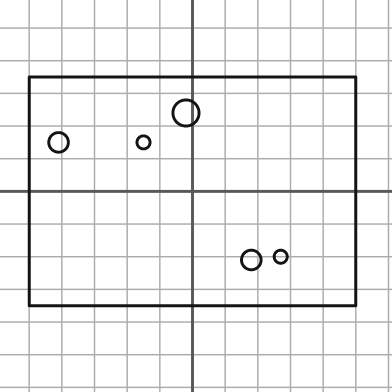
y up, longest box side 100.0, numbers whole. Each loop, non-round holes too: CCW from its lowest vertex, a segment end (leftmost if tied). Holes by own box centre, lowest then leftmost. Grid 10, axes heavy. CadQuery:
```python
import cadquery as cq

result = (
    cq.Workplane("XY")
    .moveTo(-50.0, -35.0)
    .lineTo(50.0, -35.0)
    .lineTo(50.0, 35.0)
    .lineTo(-50.0, 35.0)
    .close()
    .moveTo(18.0, -21.0)
    .circle(3.0)
    .moveTo(27.0, -20.0)
    .circle(2.0)
    .moveTo(-41.0, 15.0)
    .circle(3.0)
    .moveTo(-15.0, 15.0)
    .circle(2.0)
    .moveTo(-2.0, 24.0)
    .circle(4.0)
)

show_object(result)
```